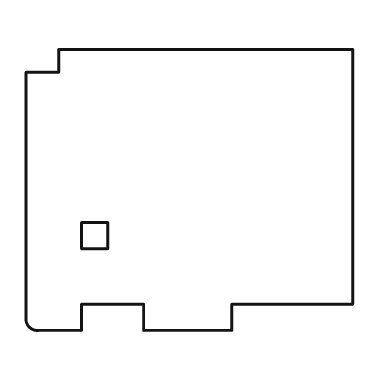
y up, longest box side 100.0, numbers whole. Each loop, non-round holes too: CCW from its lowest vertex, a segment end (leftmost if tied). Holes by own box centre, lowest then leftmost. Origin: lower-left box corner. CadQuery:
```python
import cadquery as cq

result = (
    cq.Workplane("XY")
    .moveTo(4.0, 0.0)
    .lineTo(17.0, 0.0)
    .lineTo(17.0, 8.0)
    .lineTo(36.0, 8.0)
    .lineTo(36.0, 0.0)
    .lineTo(63.0, 0.0)
    .lineTo(63.0, 8.0)
    .lineTo(100.0, 8.0)
    .lineTo(100.0, 86.0)
    .lineTo(10.0, 86.0)
    .lineTo(10.0, 79.0)
    .lineTo(0.0, 79.0)
    .lineTo(0.0, 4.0)
    .threePointArc((1.0, 1.0), (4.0, 0.0))
    .close()
    .moveTo(17.0, 25.0)
    .lineTo(25.0, 25.0)
    .lineTo(25.0, 33.0)
    .lineTo(17.0, 33.0)
    .close()
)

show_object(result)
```